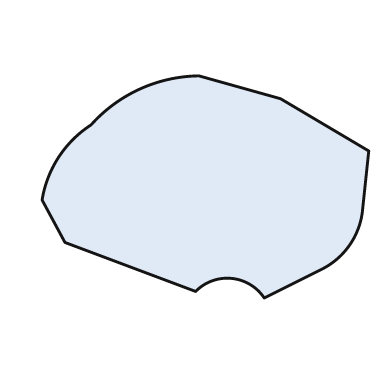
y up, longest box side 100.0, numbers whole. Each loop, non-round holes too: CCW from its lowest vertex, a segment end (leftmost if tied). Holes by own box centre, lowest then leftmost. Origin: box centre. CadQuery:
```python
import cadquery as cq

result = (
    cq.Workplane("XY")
    .moveTo(18.0, -34.0)
    .lineTo(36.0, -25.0)
    .threePointArc((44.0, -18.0), (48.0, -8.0))
    .lineTo(50.0, 11.0)
    .lineTo(23.0, 27.0)
    .lineTo(-2.0, 34.0)
    .threePointArc((-20.0, 30.0), (-35.0, 19.0))
    .threePointArc((-45.0, 9.0), (-50.0, -4.0))
    .lineTo(-43.0, -17.0)
    .lineTo(-3.0, -32.0)
    .threePointArc((8.0, -28.0), (18.0, -34.0))
    .close()
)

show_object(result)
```